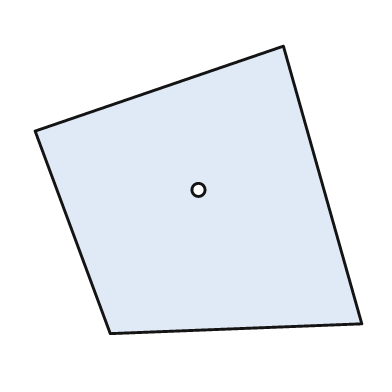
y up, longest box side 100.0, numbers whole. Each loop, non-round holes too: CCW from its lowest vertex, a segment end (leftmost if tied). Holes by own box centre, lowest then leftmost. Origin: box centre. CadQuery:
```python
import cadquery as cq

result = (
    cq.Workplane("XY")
    .moveTo(-27.0, -44.0)
    .lineTo(50.0, -41.0)
    .lineTo(26.0, 44.0)
    .lineTo(-50.0, 18.0)
    .close()
    .moveTo(0.0, 0.0)
    .circle(2.0)
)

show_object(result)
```